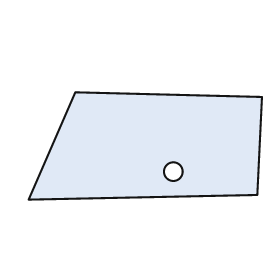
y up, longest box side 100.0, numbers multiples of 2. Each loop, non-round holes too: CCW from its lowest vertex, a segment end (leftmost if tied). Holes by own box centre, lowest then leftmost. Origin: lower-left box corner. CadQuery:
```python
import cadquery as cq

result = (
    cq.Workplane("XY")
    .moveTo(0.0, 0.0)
    .lineTo(98.0, 2.0)
    .lineTo(100.0, 44.0)
    .lineTo(20.0, 46.0)
    .close()
    .moveTo(62.0, 12.0)
    .circle(4.0)
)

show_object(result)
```